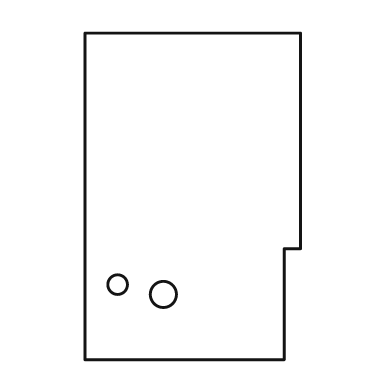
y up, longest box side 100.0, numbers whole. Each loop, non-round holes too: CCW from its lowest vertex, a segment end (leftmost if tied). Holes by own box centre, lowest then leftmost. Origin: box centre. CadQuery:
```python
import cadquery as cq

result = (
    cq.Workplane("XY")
    .moveTo(-33.0, -50.0)
    .lineTo(28.0, -50.0)
    .lineTo(28.0, -16.0)
    .lineTo(33.0, -16.0)
    .lineTo(33.0, 50.0)
    .lineTo(-33.0, 50.0)
    .close()
    .moveTo(-9.0, -30.0)
    .circle(4.0)
    .moveTo(-23.0, -27.0)
    .circle(3.0)
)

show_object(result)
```